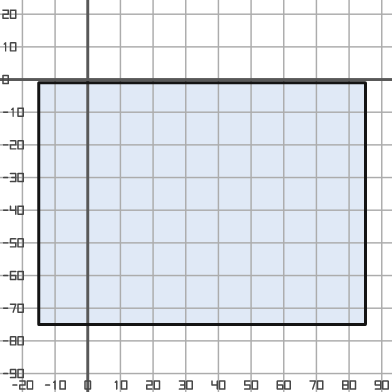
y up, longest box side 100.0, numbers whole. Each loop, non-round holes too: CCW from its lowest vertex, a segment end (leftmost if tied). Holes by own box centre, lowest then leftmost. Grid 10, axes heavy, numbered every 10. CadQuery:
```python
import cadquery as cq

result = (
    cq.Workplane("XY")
    .moveTo(-15.0, -75.0)
    .lineTo(85.0, -75.0)
    .lineTo(85.0, -1.0)
    .lineTo(-15.0, -1.0)
    .close()
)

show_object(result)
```